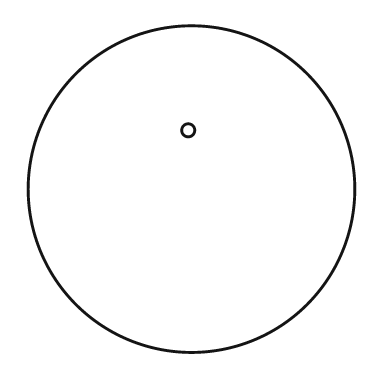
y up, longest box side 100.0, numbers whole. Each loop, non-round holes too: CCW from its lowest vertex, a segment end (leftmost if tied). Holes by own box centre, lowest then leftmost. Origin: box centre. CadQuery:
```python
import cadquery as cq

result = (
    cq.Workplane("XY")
    .moveTo(0.0, 0.0)
    .circle(50.0)
    .moveTo(-1.0, 18.0)
    .circle(2.0)
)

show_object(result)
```